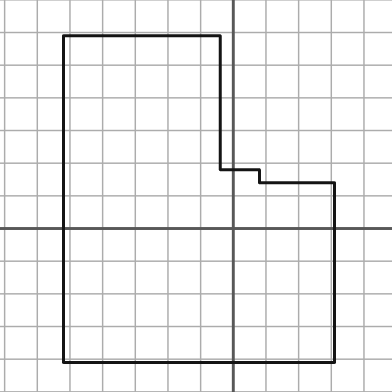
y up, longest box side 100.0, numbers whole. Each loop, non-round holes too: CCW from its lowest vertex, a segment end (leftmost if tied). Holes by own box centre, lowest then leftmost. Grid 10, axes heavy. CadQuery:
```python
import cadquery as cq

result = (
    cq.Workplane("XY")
    .moveTo(-52.0, -41.0)
    .lineTo(31.0, -41.0)
    .lineTo(31.0, 14.0)
    .lineTo(8.0, 14.0)
    .lineTo(8.0, 18.0)
    .lineTo(-4.0, 18.0)
    .lineTo(-4.0, 59.0)
    .lineTo(-52.0, 59.0)
    .close()
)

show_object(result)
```